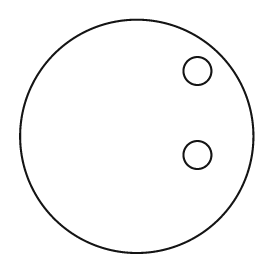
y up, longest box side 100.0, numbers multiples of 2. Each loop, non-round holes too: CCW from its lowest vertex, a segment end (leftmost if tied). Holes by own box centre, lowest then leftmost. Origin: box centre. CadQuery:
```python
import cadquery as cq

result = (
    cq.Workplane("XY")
    .moveTo(0.0, 0.0)
    .circle(50.0)
    .moveTo(26.0, -8.0)
    .circle(6.0)
    .moveTo(26.0, 28.0)
    .circle(6.0)
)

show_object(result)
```